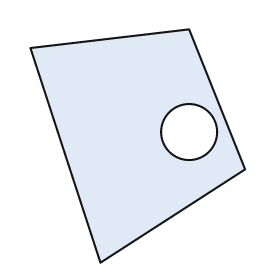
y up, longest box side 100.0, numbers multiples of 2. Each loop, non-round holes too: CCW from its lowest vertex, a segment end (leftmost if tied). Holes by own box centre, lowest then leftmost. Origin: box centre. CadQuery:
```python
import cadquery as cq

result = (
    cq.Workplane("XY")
    .moveTo(-16.0, -50.0)
    .lineTo(46.0, -10.0)
    .lineTo(22.0, 50.0)
    .lineTo(-46.0, 42.0)
    .close()
    .moveTo(22.0, 6.0)
    .circle(12.0)
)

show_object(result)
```